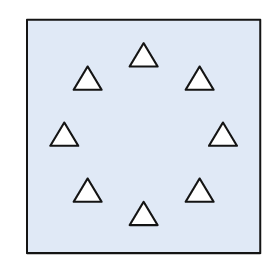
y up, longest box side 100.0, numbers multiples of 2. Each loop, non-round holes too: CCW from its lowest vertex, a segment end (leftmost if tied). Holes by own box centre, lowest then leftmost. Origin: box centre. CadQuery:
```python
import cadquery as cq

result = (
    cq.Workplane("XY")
    .moveTo(-50.0, -50.0)
    .lineTo(50.0, -50.0)
    .lineTo(50.0, 50.0)
    .lineTo(-50.0, 50.0)
    .close()
    .moveTo(-6.0, -38.0)
    .lineTo(6.0, -38.0)
    .lineTo(0.0, -28.0)
    .close()
    .moveTo(-30.0, -28.0)
    .lineTo(-18.0, -28.0)
    .lineTo(-24.0, -18.0)
    .close()
    .moveTo(18.0, -28.0)
    .lineTo(30.0, -28.0)
    .lineTo(24.0, -18.0)
    .close()
    .moveTo(-40.0, -4.0)
    .lineTo(-28.0, -4.0)
    .lineTo(-34.0, 6.0)
    .close()
    .moveTo(28.0, -4.0)
    .lineTo(40.0, -4.0)
    .lineTo(34.0, 6.0)
    .close()
    .moveTo(-30.0, 20.0)
    .lineTo(-18.0, 20.0)
    .lineTo(-24.0, 30.0)
    .close()
    .moveTo(18.0, 20.0)
    .lineTo(30.0, 20.0)
    .lineTo(24.0, 30.0)
    .close()
    .moveTo(-6.0, 30.0)
    .lineTo(6.0, 30.0)
    .lineTo(0.0, 40.0)
    .close()
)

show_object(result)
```